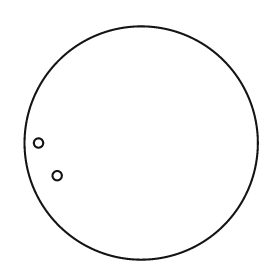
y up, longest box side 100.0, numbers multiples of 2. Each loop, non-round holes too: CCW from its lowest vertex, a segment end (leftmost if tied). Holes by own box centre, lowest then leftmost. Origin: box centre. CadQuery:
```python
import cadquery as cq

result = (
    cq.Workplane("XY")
    .moveTo(0.0, 0.0)
    .circle(50.0)
    .moveTo(-36.0, -14.0)
    .circle(2.0)
    .moveTo(-44.0, 0.0)
    .circle(2.0)
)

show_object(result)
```